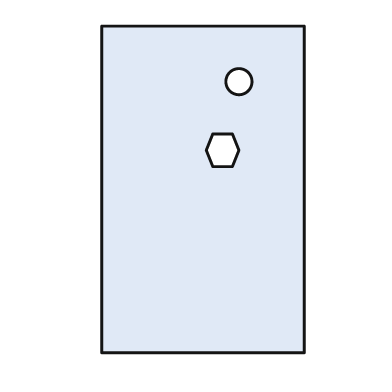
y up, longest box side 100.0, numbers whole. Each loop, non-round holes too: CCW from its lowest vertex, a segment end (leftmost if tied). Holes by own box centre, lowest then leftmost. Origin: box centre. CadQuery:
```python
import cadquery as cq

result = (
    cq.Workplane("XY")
    .moveTo(-31.0, -50.0)
    .lineTo(31.0, -50.0)
    .lineTo(31.0, 50.0)
    .lineTo(-31.0, 50.0)
    .close()
    .moveTo(3.0, 7.0)
    .lineTo(9.0, 7.0)
    .lineTo(11.0, 12.0)
    .lineTo(9.0, 17.0)
    .lineTo(3.0, 17.0)
    .lineTo(1.0, 12.0)
    .close()
    .moveTo(11.0, 33.0)
    .circle(4.0)
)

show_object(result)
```